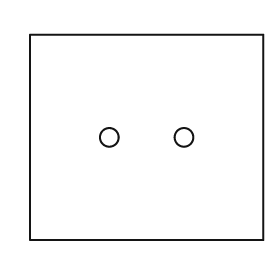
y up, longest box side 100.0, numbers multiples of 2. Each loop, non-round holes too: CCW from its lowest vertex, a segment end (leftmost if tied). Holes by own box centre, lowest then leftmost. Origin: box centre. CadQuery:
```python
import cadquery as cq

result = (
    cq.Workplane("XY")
    .moveTo(-50.0, -44.0)
    .lineTo(50.0, -44.0)
    .lineTo(50.0, 44.0)
    .lineTo(-50.0, 44.0)
    .close()
    .moveTo(-16.0, 0.0)
    .circle(4.0)
    .moveTo(16.0, 0.0)
    .circle(4.0)
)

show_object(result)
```